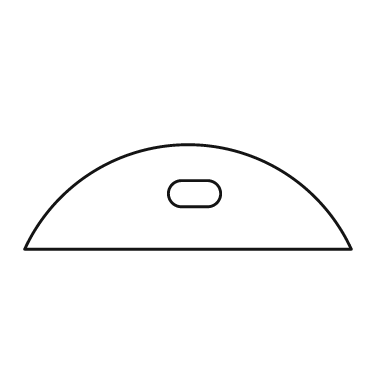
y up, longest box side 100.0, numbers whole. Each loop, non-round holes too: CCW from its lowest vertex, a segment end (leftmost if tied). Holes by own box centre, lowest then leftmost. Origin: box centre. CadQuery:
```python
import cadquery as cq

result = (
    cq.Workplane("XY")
    .moveTo(-50.0, -16.0)
    .lineTo(50.0, -16.0)
    .threePointArc((0.0, 16.0), (-50.0, -16.0))
    .close()
    .moveTo(-2.0, -3.0)
    .lineTo(6.0, -3.0)
    .threePointArc((10.0, 1.0), (6.0, 5.0))
    .lineTo(-2.0, 5.0)
    .threePointArc((-6.0, 1.0), (-2.0, -3.0))
    .close()
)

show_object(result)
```